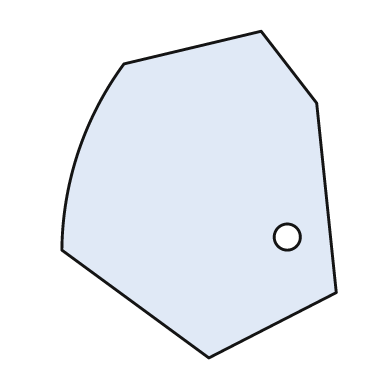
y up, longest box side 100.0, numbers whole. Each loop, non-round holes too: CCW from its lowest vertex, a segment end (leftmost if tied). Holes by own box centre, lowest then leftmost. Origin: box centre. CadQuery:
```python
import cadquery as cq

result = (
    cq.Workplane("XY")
    .moveTo(3.0, -50.0)
    .lineTo(42.0, -30.0)
    .lineTo(36.0, 28.0)
    .lineTo(19.0, 50.0)
    .lineTo(-23.0, 40.0)
    .threePointArc((-37.0, 13.0), (-42.0, -17.0))
    .close()
    .moveTo(27.0, -13.0)
    .circle(4.0)
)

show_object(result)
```